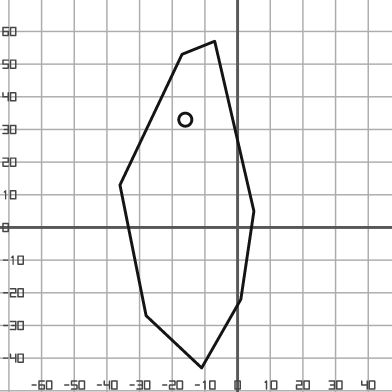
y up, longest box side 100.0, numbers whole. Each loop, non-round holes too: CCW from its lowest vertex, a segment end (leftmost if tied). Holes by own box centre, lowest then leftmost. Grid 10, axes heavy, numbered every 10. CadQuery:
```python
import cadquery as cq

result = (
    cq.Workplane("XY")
    .moveTo(-11.0, -43.0)
    .lineTo(1.0, -22.0)
    .lineTo(5.0, 5.0)
    .lineTo(-7.0, 57.0)
    .lineTo(-17.0, 53.0)
    .lineTo(-36.0, 13.0)
    .lineTo(-28.0, -27.0)
    .close()
    .moveTo(-16.0, 33.0)
    .circle(2.0)
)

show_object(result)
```